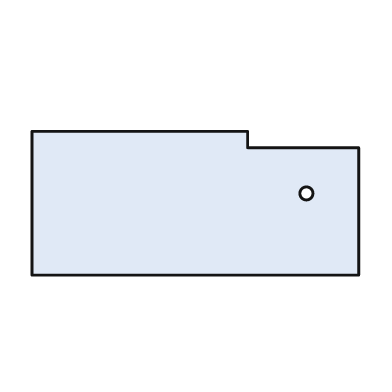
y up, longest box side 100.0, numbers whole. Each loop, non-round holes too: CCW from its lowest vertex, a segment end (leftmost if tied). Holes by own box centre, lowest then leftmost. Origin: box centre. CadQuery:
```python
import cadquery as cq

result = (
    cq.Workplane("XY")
    .moveTo(-50.0, -22.0)
    .lineTo(50.0, -22.0)
    .lineTo(50.0, 17.0)
    .lineTo(16.0, 17.0)
    .lineTo(16.0, 22.0)
    .lineTo(-50.0, 22.0)
    .close()
    .moveTo(34.0, 3.0)
    .circle(2.0)
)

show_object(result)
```